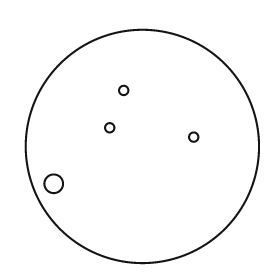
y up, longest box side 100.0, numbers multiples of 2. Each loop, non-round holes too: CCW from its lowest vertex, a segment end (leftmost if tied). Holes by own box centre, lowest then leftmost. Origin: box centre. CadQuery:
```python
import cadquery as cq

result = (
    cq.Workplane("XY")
    .moveTo(0.0, 0.0)
    .circle(50.0)
    .moveTo(-38.0, -16.0)
    .circle(4.0)
    .moveTo(22.0, 4.0)
    .circle(2.0)
    .moveTo(-14.0, 8.0)
    .circle(2.0)
    .moveTo(-8.0, 24.0)
    .circle(2.0)
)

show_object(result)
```